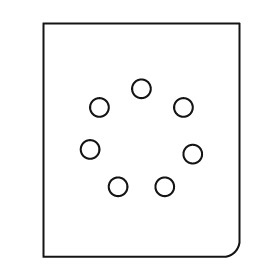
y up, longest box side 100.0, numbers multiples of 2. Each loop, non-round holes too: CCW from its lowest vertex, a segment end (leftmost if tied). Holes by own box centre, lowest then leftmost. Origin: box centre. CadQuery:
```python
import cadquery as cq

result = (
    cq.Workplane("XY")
    .moveTo(-42.0, -50.0)
    .lineTo(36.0, -50.0)
    .threePointArc((40.0, -48.0), (42.0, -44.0))
    .lineTo(42.0, 50.0)
    .lineTo(-42.0, 50.0)
    .close()
    .moveTo(-10.0, -20.0)
    .circle(4.0)
    .moveTo(10.0, -20.0)
    .circle(4.0)
    .moveTo(22.0, -6.0)
    .circle(4.0)
    .moveTo(-22.0, -4.0)
    .circle(4.0)
    .moveTo(-18.0, 14.0)
    .circle(4.0)
    .moveTo(18.0, 14.0)
    .circle(4.0)
    .moveTo(0.0, 22.0)
    .circle(4.0)
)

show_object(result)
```